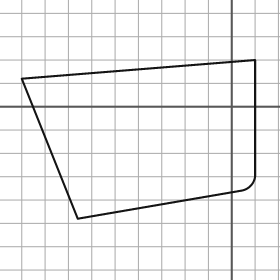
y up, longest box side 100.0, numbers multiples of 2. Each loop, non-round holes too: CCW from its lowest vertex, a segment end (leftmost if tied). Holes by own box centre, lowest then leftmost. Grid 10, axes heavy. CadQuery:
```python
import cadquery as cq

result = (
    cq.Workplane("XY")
    .moveTo(-66.0, -48.0)
    .lineTo(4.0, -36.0)
    .threePointArc((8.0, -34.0), (10.0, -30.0))
    .lineTo(10.0, 20.0)
    .lineTo(-90.0, 12.0)
    .close()
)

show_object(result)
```